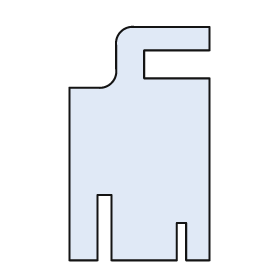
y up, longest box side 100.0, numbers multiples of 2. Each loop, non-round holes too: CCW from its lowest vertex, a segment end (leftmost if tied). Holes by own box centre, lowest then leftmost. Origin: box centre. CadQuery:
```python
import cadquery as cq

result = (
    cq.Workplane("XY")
    .moveTo(-30.0, -50.0)
    .lineTo(-18.0, -50.0)
    .lineTo(-18.0, -22.0)
    .lineTo(-12.0, -22.0)
    .lineTo(-12.0, -50.0)
    .lineTo(16.0, -50.0)
    .lineTo(16.0, -34.0)
    .lineTo(20.0, -34.0)
    .lineTo(20.0, -50.0)
    .lineTo(30.0, -50.0)
    .lineTo(30.0, 28.0)
    .lineTo(2.0, 28.0)
    .lineTo(2.0, 40.0)
    .lineTo(30.0, 40.0)
    .lineTo(30.0, 50.0)
    .lineTo(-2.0, 50.0)
    .threePointArc((-8.0, 48.0), (-10.0, 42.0))
    .lineTo(-10.0, 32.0)
    .threePointArc((-12.0, 26.0), (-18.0, 24.0))
    .lineTo(-30.0, 24.0)
    .close()
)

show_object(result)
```